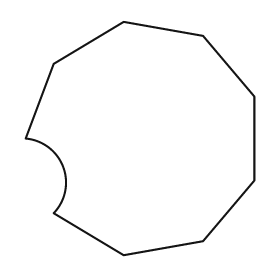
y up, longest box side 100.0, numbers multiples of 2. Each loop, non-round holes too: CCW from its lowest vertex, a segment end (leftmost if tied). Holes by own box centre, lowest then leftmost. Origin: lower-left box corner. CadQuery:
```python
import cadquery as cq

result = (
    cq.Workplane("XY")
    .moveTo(42.0, 0.0)
    .lineTo(76.0, 6.0)
    .lineTo(98.0, 32.0)
    .lineTo(98.0, 68.0)
    .lineTo(76.0, 94.0)
    .lineTo(42.0, 100.0)
    .lineTo(12.0, 82.0)
    .lineTo(0.0, 50.0)
    .threePointArc((16.0, 38.0), (12.0, 18.0))
    .close()
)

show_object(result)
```